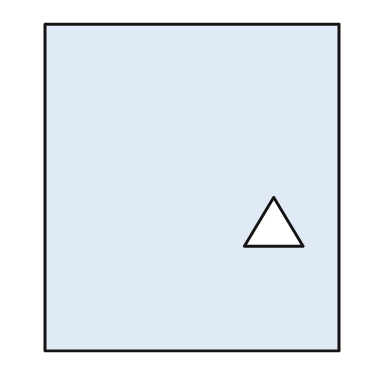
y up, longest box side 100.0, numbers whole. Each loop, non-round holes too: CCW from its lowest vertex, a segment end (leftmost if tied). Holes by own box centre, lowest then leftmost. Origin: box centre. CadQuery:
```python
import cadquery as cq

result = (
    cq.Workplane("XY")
    .moveTo(-45.0, -50.0)
    .lineTo(45.0, -50.0)
    .lineTo(45.0, 50.0)
    .lineTo(-45.0, 50.0)
    .close()
    .moveTo(16.0, -18.0)
    .lineTo(34.0, -18.0)
    .lineTo(25.0, -3.0)
    .close()
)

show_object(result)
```